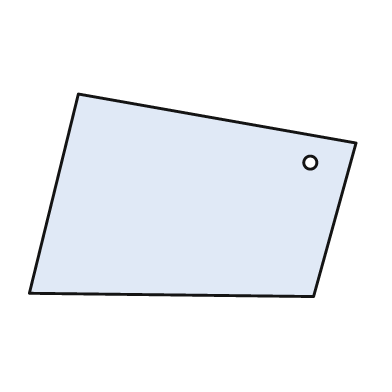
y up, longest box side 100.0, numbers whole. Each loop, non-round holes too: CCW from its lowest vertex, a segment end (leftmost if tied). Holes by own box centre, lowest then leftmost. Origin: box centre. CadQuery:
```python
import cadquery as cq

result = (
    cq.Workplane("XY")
    .moveTo(37.0, -31.0)
    .lineTo(50.0, 16.0)
    .lineTo(-35.0, 31.0)
    .lineTo(-50.0, -30.0)
    .close()
    .moveTo(36.0, 10.0)
    .circle(2.0)
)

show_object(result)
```